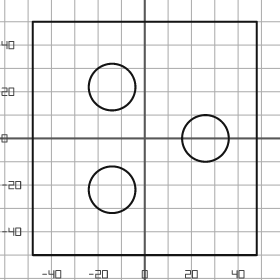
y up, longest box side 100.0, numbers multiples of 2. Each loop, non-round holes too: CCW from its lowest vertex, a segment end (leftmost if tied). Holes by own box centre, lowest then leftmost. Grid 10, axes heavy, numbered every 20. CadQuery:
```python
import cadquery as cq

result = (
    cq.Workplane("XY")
    .moveTo(-48.0, -50.0)
    .lineTo(48.0, -50.0)
    .lineTo(48.0, 50.0)
    .lineTo(-48.0, 50.0)
    .close()
    .moveTo(-14.0, -22.0)
    .circle(10.0)
    .moveTo(26.0, 0.0)
    .circle(10.0)
    .moveTo(-14.0, 22.0)
    .circle(10.0)
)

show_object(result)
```